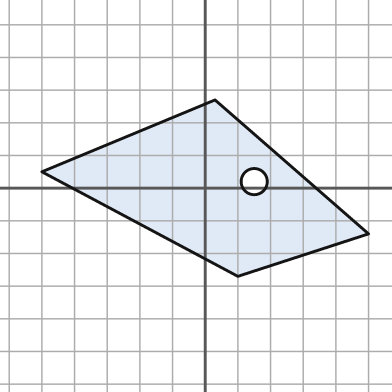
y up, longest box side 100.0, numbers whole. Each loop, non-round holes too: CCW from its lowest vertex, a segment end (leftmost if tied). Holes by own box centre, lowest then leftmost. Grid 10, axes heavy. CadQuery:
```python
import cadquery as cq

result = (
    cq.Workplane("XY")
    .moveTo(10.0, -27.0)
    .lineTo(50.0, -14.0)
    .lineTo(3.0, 27.0)
    .lineTo(-50.0, 5.0)
    .close()
    .moveTo(15.0, 2.0)
    .circle(4.0)
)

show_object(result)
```